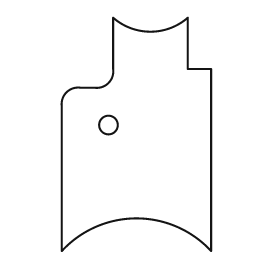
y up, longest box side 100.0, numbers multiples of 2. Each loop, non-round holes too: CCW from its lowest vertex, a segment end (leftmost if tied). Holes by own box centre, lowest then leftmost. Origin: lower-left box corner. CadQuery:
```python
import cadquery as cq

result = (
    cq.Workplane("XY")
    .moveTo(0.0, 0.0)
    .threePointArc((32.0, 14.0), (64.0, 0.0))
    .lineTo(64.0, 78.0)
    .lineTo(54.0, 78.0)
    .lineTo(54.0, 100.0)
    .threePointArc((38.0, 94.0), (22.0, 100.0))
    .lineTo(22.0, 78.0)
    .threePointArc((20.0, 72.0), (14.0, 70.0))
    .lineTo(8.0, 70.0)
    .threePointArc((2.0, 68.0), (0.0, 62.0))
    .close()
    .moveTo(20.0, 54.0)
    .circle(4.0)
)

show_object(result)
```